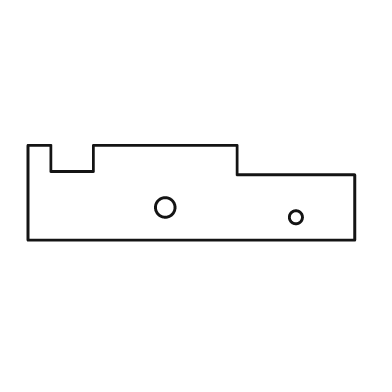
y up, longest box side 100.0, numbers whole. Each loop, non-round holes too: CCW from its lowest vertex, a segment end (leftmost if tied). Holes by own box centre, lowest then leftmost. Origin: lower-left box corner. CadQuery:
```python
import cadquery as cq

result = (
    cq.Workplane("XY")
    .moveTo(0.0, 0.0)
    .lineTo(100.0, 0.0)
    .lineTo(100.0, 20.0)
    .lineTo(64.0, 20.0)
    .lineTo(64.0, 29.0)
    .lineTo(20.0, 29.0)
    .lineTo(20.0, 21.0)
    .lineTo(7.0, 21.0)
    .lineTo(7.0, 29.0)
    .lineTo(0.0, 29.0)
    .close()
    .moveTo(82.0, 7.0)
    .circle(2.0)
    .moveTo(42.0, 10.0)
    .circle(3.0)
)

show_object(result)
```